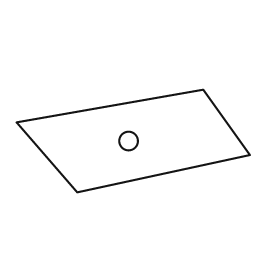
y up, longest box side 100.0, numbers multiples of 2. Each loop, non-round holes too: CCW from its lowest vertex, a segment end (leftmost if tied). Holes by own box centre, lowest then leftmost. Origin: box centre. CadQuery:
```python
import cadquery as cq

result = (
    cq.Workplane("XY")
    .moveTo(-24.0, -22.0)
    .lineTo(50.0, -6.0)
    .lineTo(30.0, 22.0)
    .lineTo(-50.0, 8.0)
    .close()
    .moveTo(-2.0, 0.0)
    .circle(4.0)
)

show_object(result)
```